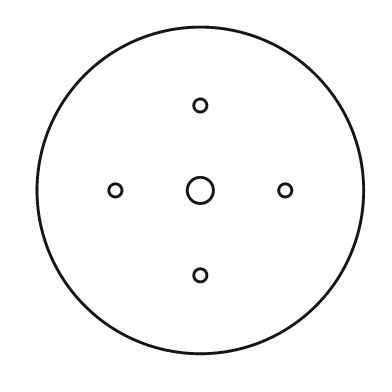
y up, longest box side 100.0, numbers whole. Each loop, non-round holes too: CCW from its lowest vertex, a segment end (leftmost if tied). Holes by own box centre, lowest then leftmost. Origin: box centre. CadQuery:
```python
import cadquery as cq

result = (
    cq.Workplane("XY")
    .moveTo(0.0, 0.0)
    .circle(50.0)
    .moveTo(0.0, -26.0)
    .circle(2.0)
    .moveTo(-26.0, 0.0)
    .circle(2.0)
    .moveTo(0.0, 0.0)
    .circle(4.0)
    .moveTo(26.0, 0.0)
    .circle(2.0)
    .moveTo(0.0, 26.0)
    .circle(2.0)
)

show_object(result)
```